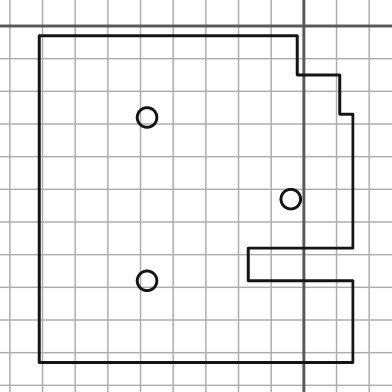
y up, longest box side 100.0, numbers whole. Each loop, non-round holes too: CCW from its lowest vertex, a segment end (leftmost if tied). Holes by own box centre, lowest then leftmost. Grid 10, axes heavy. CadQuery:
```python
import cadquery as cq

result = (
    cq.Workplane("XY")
    .moveTo(-81.0, -103.0)
    .lineTo(15.0, -103.0)
    .lineTo(15.0, -78.0)
    .lineTo(-17.0, -78.0)
    .lineTo(-17.0, -68.0)
    .lineTo(15.0, -68.0)
    .lineTo(15.0, -27.0)
    .lineTo(11.0, -27.0)
    .lineTo(11.0, -15.0)
    .lineTo(-2.0, -15.0)
    .lineTo(-2.0, -3.0)
    .lineTo(-81.0, -3.0)
    .close()
    .moveTo(-48.0, -78.0)
    .circle(3.0)
    .moveTo(-4.0, -53.0)
    .circle(3.0)
    .moveTo(-48.0, -28.0)
    .circle(3.0)
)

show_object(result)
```